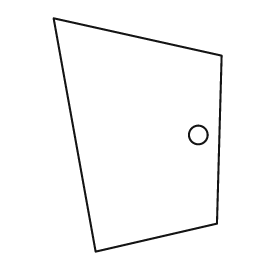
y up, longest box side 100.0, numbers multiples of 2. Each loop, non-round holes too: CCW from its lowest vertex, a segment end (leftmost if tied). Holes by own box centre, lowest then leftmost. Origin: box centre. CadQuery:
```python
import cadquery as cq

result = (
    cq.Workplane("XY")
    .moveTo(-18.0, -50.0)
    .lineTo(34.0, -38.0)
    .lineTo(36.0, 34.0)
    .lineTo(-36.0, 50.0)
    .close()
    .moveTo(26.0, 0.0)
    .circle(4.0)
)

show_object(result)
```